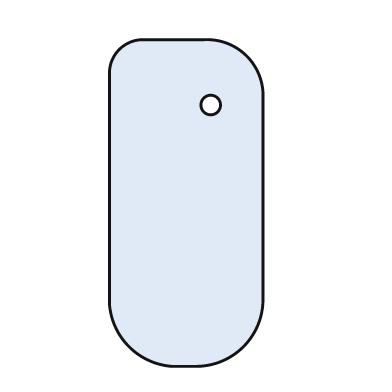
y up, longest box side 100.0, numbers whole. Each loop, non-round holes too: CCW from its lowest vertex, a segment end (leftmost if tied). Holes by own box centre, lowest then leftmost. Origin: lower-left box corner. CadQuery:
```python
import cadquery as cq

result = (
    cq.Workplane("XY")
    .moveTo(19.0, 0.0)
    .lineTo(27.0, 0.0)
    .threePointArc((41.0, 6.0), (47.0, 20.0))
    .lineTo(47.0, 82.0)
    .threePointArc((42.0, 95.0), (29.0, 100.0))
    .lineTo(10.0, 100.0)
    .threePointArc((3.0, 97.0), (0.0, 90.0))
    .lineTo(0.0, 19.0)
    .threePointArc((6.0, 6.0), (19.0, 0.0))
    .close()
    .moveTo(31.0, 80.0)
    .circle(3.0)
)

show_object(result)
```